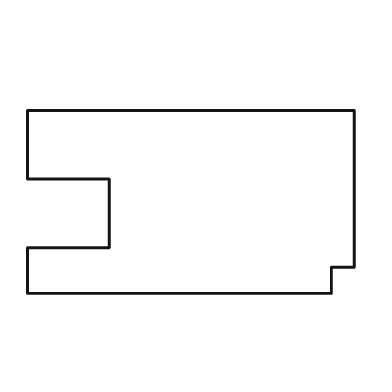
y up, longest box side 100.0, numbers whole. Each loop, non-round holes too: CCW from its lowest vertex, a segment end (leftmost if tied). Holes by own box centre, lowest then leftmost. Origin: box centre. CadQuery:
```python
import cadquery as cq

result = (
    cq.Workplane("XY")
    .moveTo(-50.0, -28.0)
    .lineTo(43.0, -28.0)
    .lineTo(43.0, -20.0)
    .lineTo(50.0, -20.0)
    .lineTo(50.0, 28.0)
    .lineTo(-50.0, 28.0)
    .lineTo(-50.0, 7.0)
    .lineTo(-25.0, 7.0)
    .lineTo(-25.0, -14.0)
    .lineTo(-50.0, -14.0)
    .close()
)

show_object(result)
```